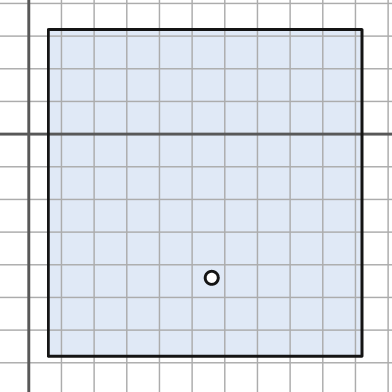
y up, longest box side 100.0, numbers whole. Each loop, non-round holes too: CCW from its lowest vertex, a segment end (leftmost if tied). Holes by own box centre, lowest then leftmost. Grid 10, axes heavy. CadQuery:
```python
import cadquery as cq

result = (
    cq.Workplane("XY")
    .moveTo(6.0, -68.0)
    .lineTo(102.0, -68.0)
    .lineTo(102.0, 32.0)
    .lineTo(6.0, 32.0)
    .close()
    .moveTo(56.0, -44.0)
    .circle(2.0)
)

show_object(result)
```